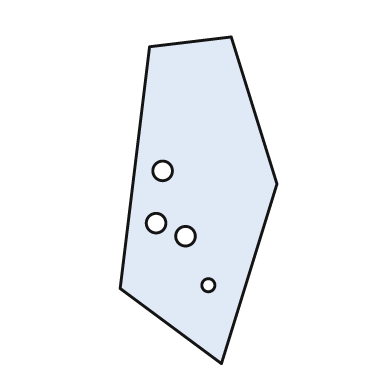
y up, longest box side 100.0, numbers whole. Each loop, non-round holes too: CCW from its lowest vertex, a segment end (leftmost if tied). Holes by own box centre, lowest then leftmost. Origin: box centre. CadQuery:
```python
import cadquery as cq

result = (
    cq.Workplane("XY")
    .moveTo(7.0, -50.0)
    .lineTo(24.0, 5.0)
    .lineTo(10.0, 50.0)
    .lineTo(-15.0, 47.0)
    .lineTo(-24.0, -27.0)
    .close()
    .moveTo(3.0, -26.0)
    .circle(2.0)
    .moveTo(-4.0, -11.0)
    .circle(3.0)
    .moveTo(-13.0, -7.0)
    .circle(3.0)
    .moveTo(-11.0, 9.0)
    .circle(3.0)
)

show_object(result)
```